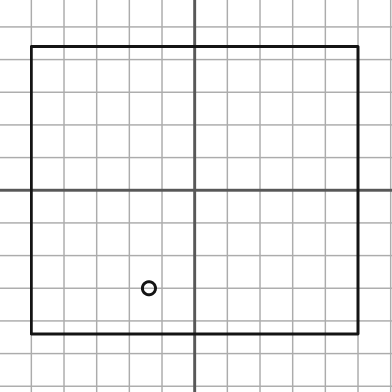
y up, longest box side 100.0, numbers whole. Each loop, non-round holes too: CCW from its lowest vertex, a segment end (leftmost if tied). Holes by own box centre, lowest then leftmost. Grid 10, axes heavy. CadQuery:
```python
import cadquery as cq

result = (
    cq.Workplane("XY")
    .moveTo(-50.0, -44.0)
    .lineTo(50.0, -44.0)
    .lineTo(50.0, 44.0)
    .lineTo(-50.0, 44.0)
    .close()
    .moveTo(-14.0, -30.0)
    .circle(2.0)
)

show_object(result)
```